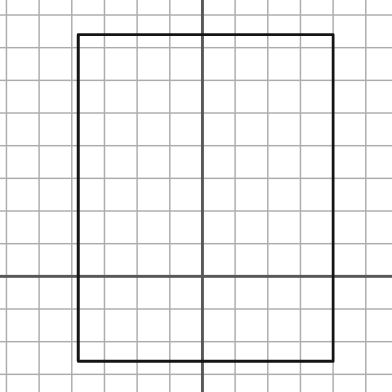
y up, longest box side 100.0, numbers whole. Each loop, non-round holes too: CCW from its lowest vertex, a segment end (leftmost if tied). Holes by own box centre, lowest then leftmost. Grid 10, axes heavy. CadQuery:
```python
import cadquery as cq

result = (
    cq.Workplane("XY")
    .moveTo(-38.0, -26.0)
    .lineTo(40.0, -26.0)
    .lineTo(40.0, 74.0)
    .lineTo(-38.0, 74.0)
    .close()
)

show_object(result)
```